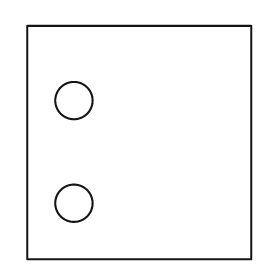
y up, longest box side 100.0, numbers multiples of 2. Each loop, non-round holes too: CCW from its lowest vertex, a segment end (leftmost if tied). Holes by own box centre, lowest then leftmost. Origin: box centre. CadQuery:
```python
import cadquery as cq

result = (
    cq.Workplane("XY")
    .moveTo(-48.0, -50.0)
    .lineTo(48.0, -50.0)
    .lineTo(48.0, 50.0)
    .lineTo(-48.0, 50.0)
    .close()
    .moveTo(-28.0, -26.0)
    .circle(8.0)
    .moveTo(-28.0, 18.0)
    .circle(8.0)
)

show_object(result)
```